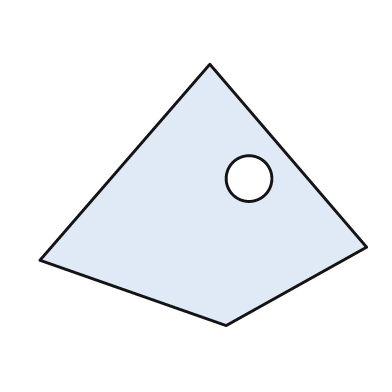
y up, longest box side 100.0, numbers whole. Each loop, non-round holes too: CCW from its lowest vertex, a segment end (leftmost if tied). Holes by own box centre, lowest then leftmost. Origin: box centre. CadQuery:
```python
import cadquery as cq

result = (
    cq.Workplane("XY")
    .moveTo(7.0, -40.0)
    .lineTo(50.0, -16.0)
    .lineTo(2.0, 40.0)
    .lineTo(-50.0, -20.0)
    .close()
    .moveTo(14.0, 5.0)
    .circle(7.0)
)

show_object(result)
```